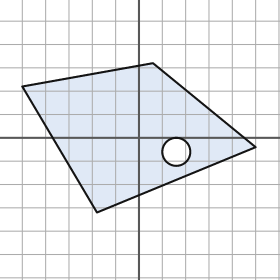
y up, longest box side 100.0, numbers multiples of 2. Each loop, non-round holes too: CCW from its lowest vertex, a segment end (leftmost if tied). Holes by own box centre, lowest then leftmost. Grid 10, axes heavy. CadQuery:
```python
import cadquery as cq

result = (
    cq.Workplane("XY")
    .moveTo(-18.0, -32.0)
    .lineTo(50.0, -4.0)
    .lineTo(6.0, 32.0)
    .lineTo(-50.0, 22.0)
    .close()
    .moveTo(16.0, -6.0)
    .circle(6.0)
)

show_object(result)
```